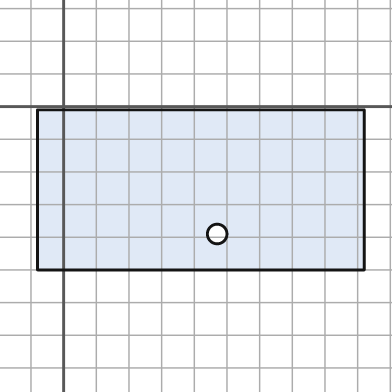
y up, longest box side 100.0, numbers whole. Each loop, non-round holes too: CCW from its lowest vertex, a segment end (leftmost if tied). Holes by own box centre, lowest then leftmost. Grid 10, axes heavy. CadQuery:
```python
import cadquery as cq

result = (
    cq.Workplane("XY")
    .moveTo(-8.0, -50.0)
    .lineTo(92.0, -50.0)
    .lineTo(92.0, -1.0)
    .lineTo(-8.0, -1.0)
    .close()
    .moveTo(47.0, -39.0)
    .circle(3.0)
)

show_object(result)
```